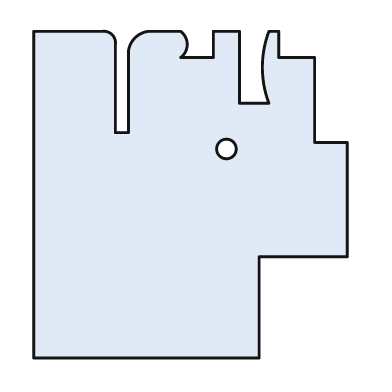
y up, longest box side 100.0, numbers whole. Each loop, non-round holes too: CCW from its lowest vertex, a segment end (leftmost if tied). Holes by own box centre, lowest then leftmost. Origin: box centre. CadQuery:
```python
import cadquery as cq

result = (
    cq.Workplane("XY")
    .moveTo(-48.0, -50.0)
    .lineTo(21.0, -50.0)
    .lineTo(21.0, -19.0)
    .lineTo(48.0, -19.0)
    .lineTo(48.0, 16.0)
    .lineTo(38.0, 16.0)
    .lineTo(38.0, 42.0)
    .lineTo(27.0, 42.0)
    .lineTo(27.0, 50.0)
    .lineTo(24.0, 50.0)
    .threePointArc((22.0, 39.0), (24.0, 28.0))
    .lineTo(15.0, 28.0)
    .lineTo(15.0, 50.0)
    .lineTo(7.0, 50.0)
    .lineTo(7.0, 42.0)
    .lineTo(-3.0, 42.0)
    .threePointArc((-1.0, 46.0), (-3.0, 50.0))
    .lineTo(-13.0, 50.0)
    .threePointArc((-17.0, 48.0), (-19.0, 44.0))
    .lineTo(-19.0, 19.0)
    .lineTo(-23.0, 19.0)
    .lineTo(-23.0, 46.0)
    .threePointArc((-24.0, 49.0), (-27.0, 50.0))
    .lineTo(-48.0, 50.0)
    .close()
    .moveTo(11.0, 14.0)
    .circle(3.0)
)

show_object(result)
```